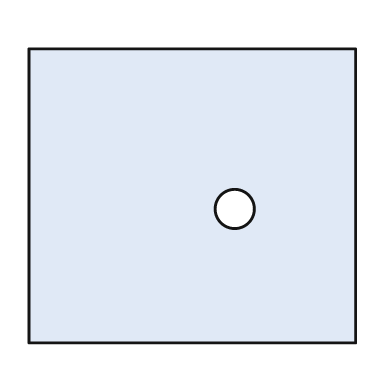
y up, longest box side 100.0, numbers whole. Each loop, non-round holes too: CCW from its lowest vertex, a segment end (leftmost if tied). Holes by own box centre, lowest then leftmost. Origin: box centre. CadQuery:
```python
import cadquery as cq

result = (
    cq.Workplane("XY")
    .moveTo(-50.0, -45.0)
    .lineTo(50.0, -45.0)
    .lineTo(50.0, 45.0)
    .lineTo(-50.0, 45.0)
    .close()
    .moveTo(13.0, -4.0)
    .circle(6.0)
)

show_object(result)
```